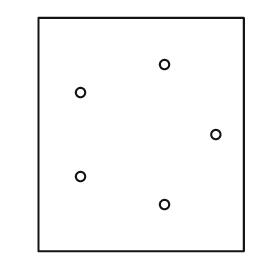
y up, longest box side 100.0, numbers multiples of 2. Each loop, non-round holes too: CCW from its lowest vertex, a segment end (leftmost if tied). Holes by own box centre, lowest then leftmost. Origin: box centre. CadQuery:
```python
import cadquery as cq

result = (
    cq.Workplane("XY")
    .moveTo(-44.0, -50.0)
    .lineTo(44.0, -50.0)
    .lineTo(44.0, 50.0)
    .lineTo(-44.0, 50.0)
    .close()
    .moveTo(10.0, -30.0)
    .circle(2.0)
    .moveTo(-26.0, -18.0)
    .circle(2.0)
    .moveTo(32.0, 0.0)
    .circle(2.0)
    .moveTo(-26.0, 18.0)
    .circle(2.0)
    .moveTo(10.0, 30.0)
    .circle(2.0)
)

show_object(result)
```